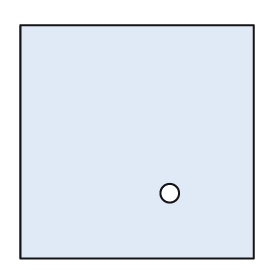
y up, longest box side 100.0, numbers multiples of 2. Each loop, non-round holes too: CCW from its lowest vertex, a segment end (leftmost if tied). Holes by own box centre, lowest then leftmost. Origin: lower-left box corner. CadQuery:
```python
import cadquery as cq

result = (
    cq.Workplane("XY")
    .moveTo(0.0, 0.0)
    .lineTo(100.0, 0.0)
    .lineTo(100.0, 100.0)
    .lineTo(0.0, 100.0)
    .close()
    .moveTo(64.0, 28.0)
    .circle(4.0)
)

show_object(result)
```